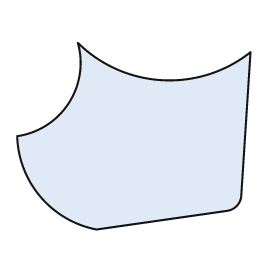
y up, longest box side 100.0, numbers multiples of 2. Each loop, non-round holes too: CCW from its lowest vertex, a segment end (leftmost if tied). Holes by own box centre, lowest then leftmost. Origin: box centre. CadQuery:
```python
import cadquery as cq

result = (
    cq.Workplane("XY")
    .moveTo(-16.0, -40.0)
    .lineTo(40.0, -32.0)
    .threePointArc((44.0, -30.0), (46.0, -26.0))
    .lineTo(50.0, 36.0)
    .threePointArc((12.0, 24.0), (-24.0, 40.0))
    .threePointArc((-28.0, 14.0), (-50.0, 0.0))
    .threePointArc((-40.0, -26.0), (-16.0, -40.0))
    .close()
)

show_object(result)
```